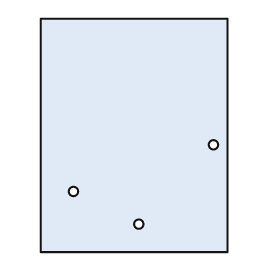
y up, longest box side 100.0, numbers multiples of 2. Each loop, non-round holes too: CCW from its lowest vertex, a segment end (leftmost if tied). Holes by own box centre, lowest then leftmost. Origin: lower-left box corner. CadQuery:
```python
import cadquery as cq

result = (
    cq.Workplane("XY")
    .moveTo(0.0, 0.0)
    .lineTo(80.0, 0.0)
    .lineTo(80.0, 100.0)
    .lineTo(0.0, 100.0)
    .close()
    .moveTo(42.0, 12.0)
    .circle(2.0)
    .moveTo(14.0, 26.0)
    .circle(2.0)
    .moveTo(74.0, 46.0)
    .circle(2.0)
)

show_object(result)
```